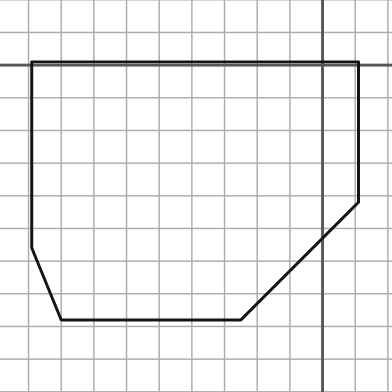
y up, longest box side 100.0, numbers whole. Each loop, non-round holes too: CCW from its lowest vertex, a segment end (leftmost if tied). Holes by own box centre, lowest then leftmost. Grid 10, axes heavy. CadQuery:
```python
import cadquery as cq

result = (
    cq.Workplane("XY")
    .moveTo(-80.0, -78.0)
    .lineTo(-25.0, -78.0)
    .lineTo(11.0, -42.0)
    .lineTo(11.0, 1.0)
    .lineTo(-89.0, 1.0)
    .lineTo(-89.0, -56.0)
    .close()
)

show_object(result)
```